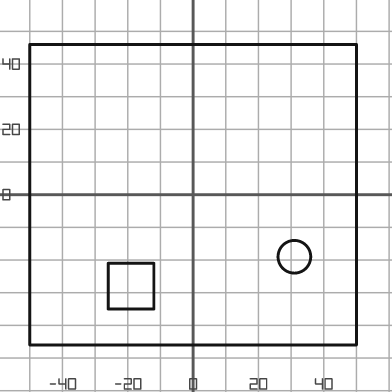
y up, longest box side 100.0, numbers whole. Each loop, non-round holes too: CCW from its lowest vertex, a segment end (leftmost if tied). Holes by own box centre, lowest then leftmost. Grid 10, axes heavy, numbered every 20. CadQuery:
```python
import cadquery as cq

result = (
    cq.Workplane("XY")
    .moveTo(-50.0, -46.0)
    .lineTo(50.0, -46.0)
    .lineTo(50.0, 46.0)
    .lineTo(-50.0, 46.0)
    .close()
    .moveTo(-26.0, -35.0)
    .lineTo(-12.0, -35.0)
    .lineTo(-12.0, -21.0)
    .lineTo(-26.0, -21.0)
    .close()
    .moveTo(31.0, -19.0)
    .circle(5.0)
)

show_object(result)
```